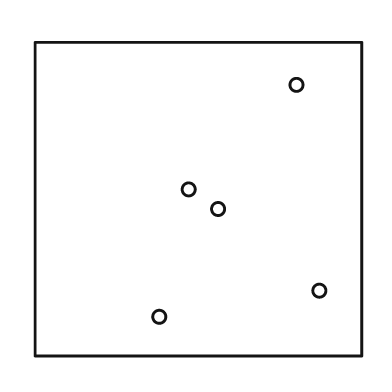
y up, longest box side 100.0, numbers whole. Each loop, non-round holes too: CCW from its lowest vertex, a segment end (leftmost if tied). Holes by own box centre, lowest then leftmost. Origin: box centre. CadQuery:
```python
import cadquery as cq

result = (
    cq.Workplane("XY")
    .moveTo(-50.0, -48.0)
    .lineTo(50.0, -48.0)
    .lineTo(50.0, 48.0)
    .lineTo(-50.0, 48.0)
    .close()
    .moveTo(-12.0, -36.0)
    .circle(2.0)
    .moveTo(37.0, -28.0)
    .circle(2.0)
    .moveTo(6.0, -3.0)
    .circle(2.0)
    .moveTo(-3.0, 3.0)
    .circle(2.0)
    .moveTo(30.0, 35.0)
    .circle(2.0)
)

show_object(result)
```